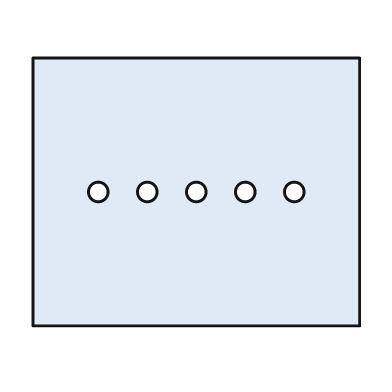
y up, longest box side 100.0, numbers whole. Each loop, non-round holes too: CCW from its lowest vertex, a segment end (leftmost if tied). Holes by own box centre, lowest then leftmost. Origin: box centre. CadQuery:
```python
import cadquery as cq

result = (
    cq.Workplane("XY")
    .moveTo(-50.0, -41.0)
    .lineTo(50.0, -41.0)
    .lineTo(50.0, 41.0)
    .lineTo(-50.0, 41.0)
    .close()
    .moveTo(-30.0, 0.0)
    .circle(3.0)
    .moveTo(-15.0, 0.0)
    .circle(3.0)
    .moveTo(0.0, 0.0)
    .circle(3.0)
    .moveTo(15.0, 0.0)
    .circle(3.0)
    .moveTo(30.0, 0.0)
    .circle(3.0)
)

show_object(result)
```